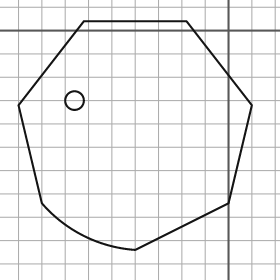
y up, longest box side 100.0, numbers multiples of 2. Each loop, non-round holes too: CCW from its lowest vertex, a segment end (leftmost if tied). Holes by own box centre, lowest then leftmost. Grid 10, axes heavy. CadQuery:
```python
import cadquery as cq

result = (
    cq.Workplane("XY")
    .moveTo(-40.0, -94.0)
    .lineTo(0.0, -74.0)
    .lineTo(10.0, -32.0)
    .lineTo(-18.0, 4.0)
    .lineTo(-62.0, 4.0)
    .lineTo(-90.0, -32.0)
    .lineTo(-80.0, -74.0)
    .threePointArc((-62.0, -88.0), (-40.0, -94.0))
    .close()
    .moveTo(-66.0, -30.0)
    .circle(4.0)
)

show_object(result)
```